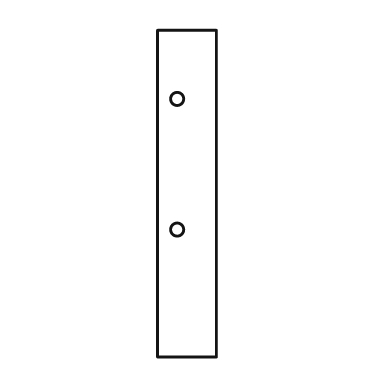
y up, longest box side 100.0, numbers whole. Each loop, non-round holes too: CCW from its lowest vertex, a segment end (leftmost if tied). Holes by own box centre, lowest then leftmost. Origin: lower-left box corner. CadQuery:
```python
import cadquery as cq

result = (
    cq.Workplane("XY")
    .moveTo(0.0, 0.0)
    .lineTo(18.0, 0.0)
    .lineTo(18.0, 100.0)
    .lineTo(0.0, 100.0)
    .close()
    .moveTo(6.0, 39.0)
    .circle(2.0)
    .moveTo(6.0, 79.0)
    .circle(2.0)
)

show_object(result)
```